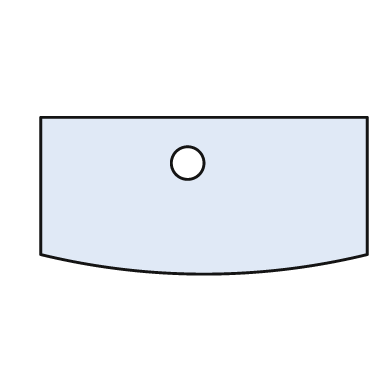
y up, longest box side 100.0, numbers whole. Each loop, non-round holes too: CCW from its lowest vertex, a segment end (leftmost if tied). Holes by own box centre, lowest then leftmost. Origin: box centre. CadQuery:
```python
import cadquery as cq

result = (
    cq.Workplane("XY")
    .moveTo(-50.0, -18.0)
    .threePointArc((0.0, -24.0), (50.0, -18.0))
    .lineTo(50.0, 24.0)
    .lineTo(-50.0, 24.0)
    .close()
    .moveTo(-5.0, 10.0)
    .circle(5.0)
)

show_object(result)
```